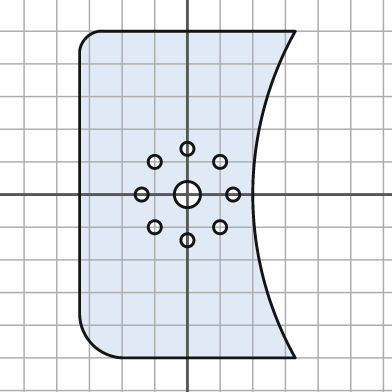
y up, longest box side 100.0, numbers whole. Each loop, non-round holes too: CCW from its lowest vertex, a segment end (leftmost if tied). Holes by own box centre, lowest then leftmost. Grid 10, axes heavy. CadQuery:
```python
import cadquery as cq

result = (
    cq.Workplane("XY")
    .moveTo(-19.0, -50.0)
    .lineTo(33.0, -50.0)
    .threePointArc((20.0, 0.0), (33.0, 50.0))
    .lineTo(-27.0, 50.0)
    .threePointArc((-31.0, 48.0), (-33.0, 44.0))
    .lineTo(-33.0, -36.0)
    .threePointArc((-29.0, -46.0), (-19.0, -50.0))
    .close()
    .moveTo(0.0, -14.0)
    .circle(2.0)
    .moveTo(-10.0, -10.0)
    .circle(2.0)
    .moveTo(10.0, -10.0)
    .circle(2.0)
    .moveTo(-14.0, 0.0)
    .circle(2.0)
    .moveTo(0.0, 0.0)
    .circle(4.0)
    .moveTo(14.0, 0.0)
    .circle(2.0)
    .moveTo(-10.0, 10.0)
    .circle(2.0)
    .moveTo(10.0, 10.0)
    .circle(2.0)
    .moveTo(0.0, 14.0)
    .circle(2.0)
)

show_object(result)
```